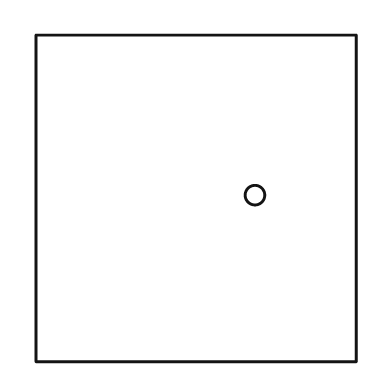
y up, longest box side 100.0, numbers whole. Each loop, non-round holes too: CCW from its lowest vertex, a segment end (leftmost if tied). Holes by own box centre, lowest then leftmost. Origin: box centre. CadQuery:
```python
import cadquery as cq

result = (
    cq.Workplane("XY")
    .moveTo(-49.0, -50.0)
    .lineTo(49.0, -50.0)
    .lineTo(49.0, 50.0)
    .lineTo(-49.0, 50.0)
    .close()
    .moveTo(18.0, 1.0)
    .circle(3.0)
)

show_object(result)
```